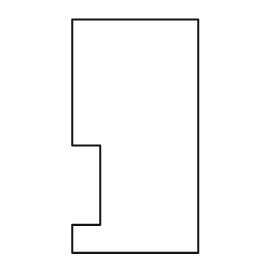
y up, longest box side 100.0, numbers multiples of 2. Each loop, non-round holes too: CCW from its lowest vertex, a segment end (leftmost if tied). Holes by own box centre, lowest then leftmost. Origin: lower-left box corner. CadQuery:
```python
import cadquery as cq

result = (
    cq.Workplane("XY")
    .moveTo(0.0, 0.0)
    .lineTo(54.0, 0.0)
    .lineTo(54.0, 100.0)
    .lineTo(0.0, 100.0)
    .lineTo(0.0, 46.0)
    .lineTo(12.0, 46.0)
    .lineTo(12.0, 12.0)
    .lineTo(0.0, 12.0)
    .close()
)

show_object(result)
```